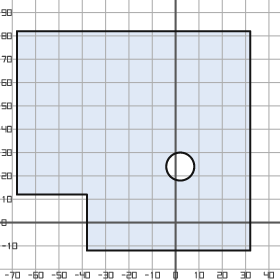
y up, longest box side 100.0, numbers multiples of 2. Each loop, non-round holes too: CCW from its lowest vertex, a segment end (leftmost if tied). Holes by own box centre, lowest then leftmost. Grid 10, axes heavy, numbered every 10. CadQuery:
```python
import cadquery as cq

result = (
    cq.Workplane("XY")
    .moveTo(-38.0, -12.0)
    .lineTo(32.0, -12.0)
    .lineTo(32.0, 82.0)
    .lineTo(-68.0, 82.0)
    .lineTo(-68.0, 12.0)
    .lineTo(-38.0, 12.0)
    .close()
    .moveTo(2.0, 24.0)
    .circle(6.0)
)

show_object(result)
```